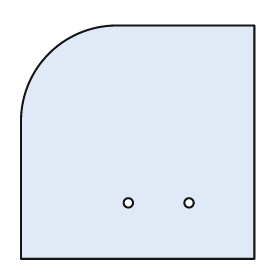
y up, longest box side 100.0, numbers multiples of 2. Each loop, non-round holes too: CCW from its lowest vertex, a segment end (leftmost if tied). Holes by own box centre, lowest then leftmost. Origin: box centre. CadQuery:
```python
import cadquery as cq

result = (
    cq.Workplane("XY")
    .moveTo(-50.0, -50.0)
    .lineTo(50.0, -50.0)
    .lineTo(50.0, 50.0)
    .lineTo(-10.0, 50.0)
    .threePointArc((-38.0, 38.0), (-50.0, 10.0))
    .close()
    .moveTo(-4.0, -26.0)
    .circle(2.0)
    .moveTo(22.0, -26.0)
    .circle(2.0)
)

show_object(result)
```